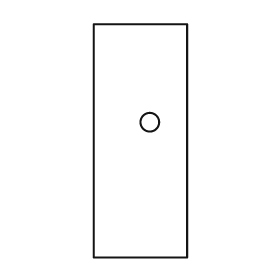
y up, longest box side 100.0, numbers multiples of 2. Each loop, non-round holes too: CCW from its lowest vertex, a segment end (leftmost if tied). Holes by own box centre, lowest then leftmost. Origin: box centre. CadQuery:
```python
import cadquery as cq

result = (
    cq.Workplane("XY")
    .moveTo(-20.0, -50.0)
    .lineTo(20.0, -50.0)
    .lineTo(20.0, 50.0)
    .lineTo(-20.0, 50.0)
    .close()
    .moveTo(4.0, 8.0)
    .circle(4.0)
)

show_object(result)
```